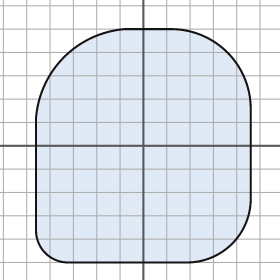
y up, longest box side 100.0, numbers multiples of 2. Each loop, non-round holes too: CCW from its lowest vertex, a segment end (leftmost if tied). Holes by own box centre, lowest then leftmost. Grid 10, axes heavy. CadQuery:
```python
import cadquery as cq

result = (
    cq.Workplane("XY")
    .moveTo(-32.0, -50.0)
    .lineTo(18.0, -50.0)
    .threePointArc((38.0, -42.0), (46.0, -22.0))
    .lineTo(46.0, 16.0)
    .threePointArc((36.0, 40.0), (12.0, 50.0))
    .lineTo(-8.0, 50.0)
    .threePointArc((-34.0, 38.0), (-46.0, 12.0))
    .lineTo(-46.0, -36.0)
    .threePointArc((-42.0, -46.0), (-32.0, -50.0))
    .close()
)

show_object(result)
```